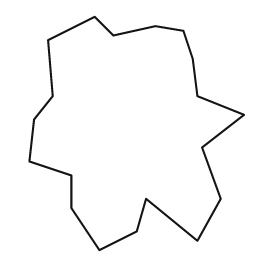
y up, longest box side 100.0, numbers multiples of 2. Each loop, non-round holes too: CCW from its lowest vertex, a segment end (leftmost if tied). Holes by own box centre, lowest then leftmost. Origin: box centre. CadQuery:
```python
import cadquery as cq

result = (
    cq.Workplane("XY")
    .moveTo(-16.0, -50.0)
    .lineTo(0.0, -42.0)
    .lineTo(4.0, -28.0)
    .lineTo(26.0, -46.0)
    .lineTo(36.0, -28.0)
    .lineTo(28.0, -6.0)
    .lineTo(46.0, 8.0)
    .lineTo(26.0, 16.0)
    .lineTo(24.0, 32.0)
    .lineTo(20.0, 44.0)
    .lineTo(8.0, 46.0)
    .lineTo(-10.0, 42.0)
    .lineTo(-18.0, 50.0)
    .lineTo(-38.0, 40.0)
    .lineTo(-36.0, 16.0)
    .lineTo(-44.0, 6.0)
    .lineTo(-46.0, -12.0)
    .lineTo(-28.0, -18.0)
    .lineTo(-28.0, -32.0)
    .close()
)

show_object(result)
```